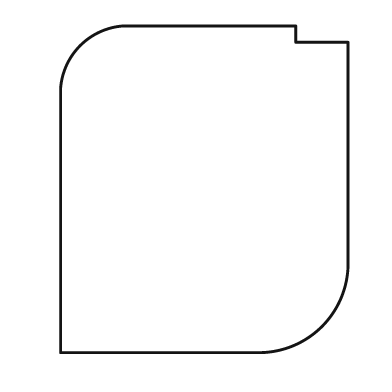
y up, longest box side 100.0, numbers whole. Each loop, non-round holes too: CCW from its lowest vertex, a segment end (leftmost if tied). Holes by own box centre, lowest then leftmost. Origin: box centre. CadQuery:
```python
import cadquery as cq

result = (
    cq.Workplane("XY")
    .moveTo(-44.0, -50.0)
    .lineTo(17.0, -50.0)
    .threePointArc((36.0, -42.0), (44.0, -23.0))
    .lineTo(44.0, 45.0)
    .lineTo(28.0, 45.0)
    .lineTo(28.0, 50.0)
    .lineTo(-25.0, 50.0)
    .threePointArc((-38.0, 44.0), (-44.0, 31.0))
    .close()
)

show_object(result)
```